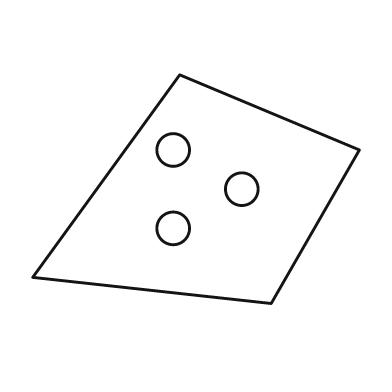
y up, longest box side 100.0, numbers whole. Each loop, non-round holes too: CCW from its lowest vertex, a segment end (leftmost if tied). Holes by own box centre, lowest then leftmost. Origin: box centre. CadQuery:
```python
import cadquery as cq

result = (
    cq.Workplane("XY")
    .moveTo(23.0, -35.0)
    .lineTo(50.0, 12.0)
    .lineTo(-5.0, 35.0)
    .lineTo(-50.0, -27.0)
    .close()
    .moveTo(-7.0, -12.0)
    .circle(5.0)
    .moveTo(14.0, 0.0)
    .circle(5.0)
    .moveTo(-7.0, 12.0)
    .circle(5.0)
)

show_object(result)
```